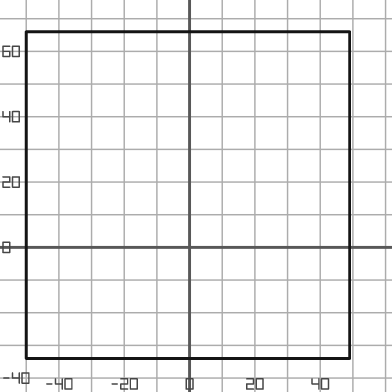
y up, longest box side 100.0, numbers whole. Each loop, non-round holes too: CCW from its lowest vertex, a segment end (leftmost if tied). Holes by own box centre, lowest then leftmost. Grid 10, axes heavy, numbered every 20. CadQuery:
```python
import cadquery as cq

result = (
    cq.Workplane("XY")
    .moveTo(-50.0, -34.0)
    .lineTo(49.0, -34.0)
    .lineTo(49.0, 66.0)
    .lineTo(-50.0, 66.0)
    .close()
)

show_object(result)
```